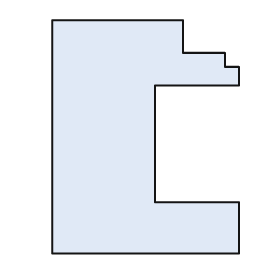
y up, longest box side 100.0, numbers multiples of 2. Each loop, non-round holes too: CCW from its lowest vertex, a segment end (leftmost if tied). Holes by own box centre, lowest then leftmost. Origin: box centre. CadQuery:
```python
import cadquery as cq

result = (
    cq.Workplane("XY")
    .moveTo(-40.0, -50.0)
    .lineTo(40.0, -50.0)
    .lineTo(40.0, -28.0)
    .lineTo(4.0, -28.0)
    .lineTo(4.0, 22.0)
    .lineTo(40.0, 22.0)
    .lineTo(40.0, 30.0)
    .lineTo(34.0, 30.0)
    .lineTo(34.0, 36.0)
    .lineTo(16.0, 36.0)
    .lineTo(16.0, 50.0)
    .lineTo(-40.0, 50.0)
    .close()
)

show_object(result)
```